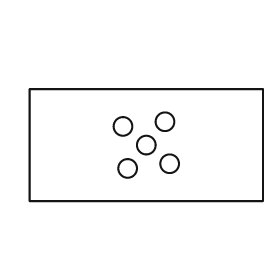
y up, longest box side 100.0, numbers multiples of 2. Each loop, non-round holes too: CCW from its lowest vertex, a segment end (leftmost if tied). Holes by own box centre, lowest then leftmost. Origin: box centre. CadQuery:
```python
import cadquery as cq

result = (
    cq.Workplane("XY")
    .moveTo(-50.0, -24.0)
    .lineTo(50.0, -24.0)
    .lineTo(50.0, 24.0)
    .lineTo(-50.0, 24.0)
    .close()
    .moveTo(-8.0, -10.0)
    .circle(4.0)
    .moveTo(10.0, -8.0)
    .circle(4.0)
    .moveTo(0.0, 0.0)
    .circle(4.0)
    .moveTo(-10.0, 8.0)
    .circle(4.0)
    .moveTo(8.0, 10.0)
    .circle(4.0)
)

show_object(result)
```